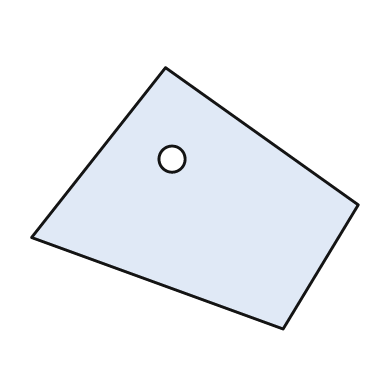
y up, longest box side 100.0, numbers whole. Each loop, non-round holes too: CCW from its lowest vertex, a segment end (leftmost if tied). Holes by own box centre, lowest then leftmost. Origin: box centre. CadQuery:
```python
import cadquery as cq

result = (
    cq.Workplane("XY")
    .moveTo(27.0, -40.0)
    .lineTo(50.0, -2.0)
    .lineTo(-9.0, 40.0)
    .lineTo(-50.0, -12.0)
    .close()
    .moveTo(-7.0, 12.0)
    .circle(4.0)
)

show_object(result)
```